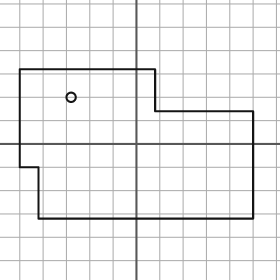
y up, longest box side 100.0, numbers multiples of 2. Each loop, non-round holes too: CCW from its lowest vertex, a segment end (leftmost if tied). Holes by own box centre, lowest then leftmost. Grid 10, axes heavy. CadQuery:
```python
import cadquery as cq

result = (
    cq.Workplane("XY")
    .moveTo(-42.0, -32.0)
    .lineTo(50.0, -32.0)
    .lineTo(50.0, 14.0)
    .lineTo(8.0, 14.0)
    .lineTo(8.0, 32.0)
    .lineTo(-50.0, 32.0)
    .lineTo(-50.0, -10.0)
    .lineTo(-42.0, -10.0)
    .close()
    .moveTo(-28.0, 20.0)
    .circle(2.0)
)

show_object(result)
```